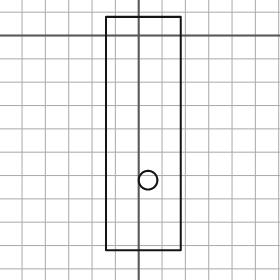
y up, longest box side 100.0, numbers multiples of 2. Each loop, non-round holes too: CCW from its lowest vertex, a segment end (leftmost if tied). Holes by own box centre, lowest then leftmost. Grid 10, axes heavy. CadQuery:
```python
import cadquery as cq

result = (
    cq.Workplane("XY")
    .moveTo(-14.0, -92.0)
    .lineTo(18.0, -92.0)
    .lineTo(18.0, 8.0)
    .lineTo(-14.0, 8.0)
    .close()
    .moveTo(4.0, -62.0)
    .circle(4.0)
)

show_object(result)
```